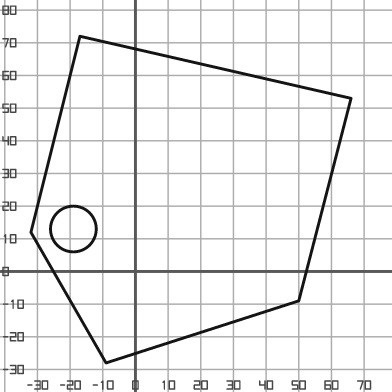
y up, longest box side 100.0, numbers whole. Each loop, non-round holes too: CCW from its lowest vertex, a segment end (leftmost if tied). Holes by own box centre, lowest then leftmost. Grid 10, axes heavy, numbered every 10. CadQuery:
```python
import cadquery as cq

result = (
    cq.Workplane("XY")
    .moveTo(-9.0, -28.0)
    .lineTo(50.0, -9.0)
    .lineTo(66.0, 53.0)
    .lineTo(-17.0, 72.0)
    .lineTo(-32.0, 12.0)
    .close()
    .moveTo(-19.0, 13.0)
    .circle(7.0)
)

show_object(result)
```